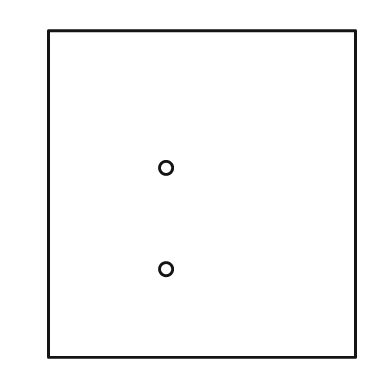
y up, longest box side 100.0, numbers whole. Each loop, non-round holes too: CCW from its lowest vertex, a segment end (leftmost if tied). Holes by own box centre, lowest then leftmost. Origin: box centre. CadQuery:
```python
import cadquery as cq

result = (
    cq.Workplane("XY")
    .moveTo(-47.0, -50.0)
    .lineTo(47.0, -50.0)
    .lineTo(47.0, 50.0)
    .lineTo(-47.0, 50.0)
    .close()
    .moveTo(-11.0, -23.0)
    .circle(2.0)
    .moveTo(-11.0, 8.0)
    .circle(2.0)
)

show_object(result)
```